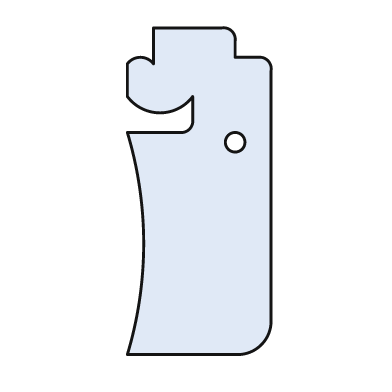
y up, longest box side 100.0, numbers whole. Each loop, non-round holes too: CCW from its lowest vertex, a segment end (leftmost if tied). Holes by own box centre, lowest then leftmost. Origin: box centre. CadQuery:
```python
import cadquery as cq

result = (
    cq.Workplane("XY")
    .moveTo(-22.0, -50.0)
    .lineTo(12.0, -50.0)
    .threePointArc((19.0, -47.0), (22.0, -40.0))
    .lineTo(22.0, 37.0)
    .threePointArc((21.0, 40.0), (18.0, 41.0))
    .lineTo(11.0, 41.0)
    .lineTo(11.0, 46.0)
    .threePointArc((10.0, 49.0), (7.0, 50.0))
    .lineTo(-14.0, 50.0)
    .lineTo(-14.0, 39.0)
    .threePointArc((-18.0, 41.0), (-22.0, 39.0))
    .lineTo(-22.0, 29.0)
    .threePointArc((-12.0, 24.0), (-2.0, 29.0))
    .lineTo(-2.0, 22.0)
    .threePointArc((-3.0, 19.0), (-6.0, 18.0))
    .lineTo(-22.0, 18.0)
    .threePointArc((-17.0, -16.0), (-22.0, -50.0))
    .close()
    .moveTo(11.0, 15.0)
    .circle(3.0)
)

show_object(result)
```